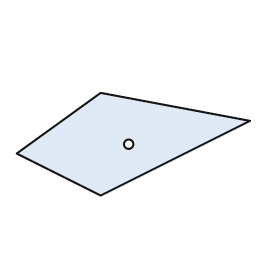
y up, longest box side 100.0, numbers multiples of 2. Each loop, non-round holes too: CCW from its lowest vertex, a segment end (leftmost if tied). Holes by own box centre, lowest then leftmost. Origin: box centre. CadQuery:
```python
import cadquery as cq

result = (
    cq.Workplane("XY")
    .moveTo(-14.0, -22.0)
    .lineTo(50.0, 10.0)
    .lineTo(-14.0, 22.0)
    .lineTo(-50.0, -4.0)
    .close()
    .moveTo(-2.0, 0.0)
    .circle(2.0)
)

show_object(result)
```